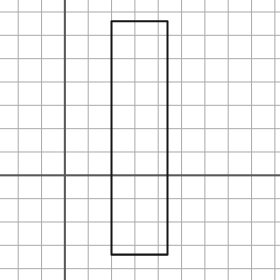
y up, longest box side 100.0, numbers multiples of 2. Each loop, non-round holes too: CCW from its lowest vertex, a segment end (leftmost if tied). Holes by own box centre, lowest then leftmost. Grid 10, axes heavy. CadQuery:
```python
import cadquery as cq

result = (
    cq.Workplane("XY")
    .moveTo(20.0, -34.0)
    .lineTo(44.0, -34.0)
    .lineTo(44.0, 66.0)
    .lineTo(20.0, 66.0)
    .close()
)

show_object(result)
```